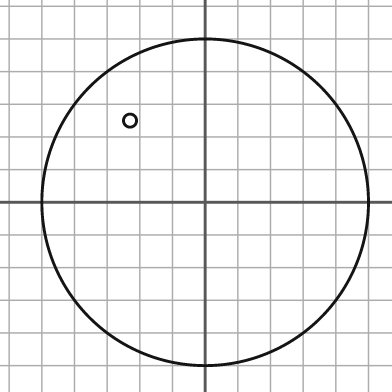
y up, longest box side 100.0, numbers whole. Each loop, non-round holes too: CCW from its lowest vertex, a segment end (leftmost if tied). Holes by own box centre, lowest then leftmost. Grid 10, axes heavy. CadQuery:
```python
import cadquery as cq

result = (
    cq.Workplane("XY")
    .moveTo(0.0, 0.0)
    .circle(50.0)
    .moveTo(-23.0, 25.0)
    .circle(2.0)
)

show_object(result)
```